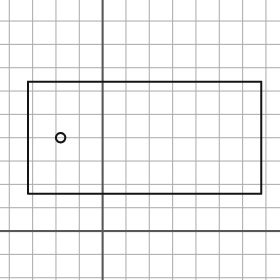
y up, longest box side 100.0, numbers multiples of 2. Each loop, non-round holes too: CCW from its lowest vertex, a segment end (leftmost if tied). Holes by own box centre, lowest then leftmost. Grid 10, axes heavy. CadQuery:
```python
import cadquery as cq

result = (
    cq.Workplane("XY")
    .moveTo(-32.0, 16.0)
    .lineTo(68.0, 16.0)
    .lineTo(68.0, 64.0)
    .lineTo(-32.0, 64.0)
    .close()
    .moveTo(-18.0, 40.0)
    .circle(2.0)
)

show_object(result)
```